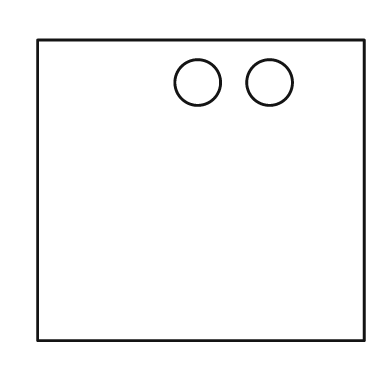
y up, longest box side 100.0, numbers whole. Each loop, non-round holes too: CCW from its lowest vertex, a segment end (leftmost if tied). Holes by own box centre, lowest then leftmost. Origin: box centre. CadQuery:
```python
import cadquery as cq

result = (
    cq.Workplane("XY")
    .moveTo(-50.0, -46.0)
    .lineTo(50.0, -46.0)
    .lineTo(50.0, 46.0)
    .lineTo(-50.0, 46.0)
    .close()
    .moveTo(-1.0, 33.0)
    .circle(7.0)
    .moveTo(21.0, 33.0)
    .circle(7.0)
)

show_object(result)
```